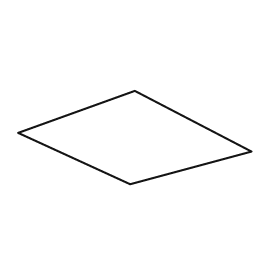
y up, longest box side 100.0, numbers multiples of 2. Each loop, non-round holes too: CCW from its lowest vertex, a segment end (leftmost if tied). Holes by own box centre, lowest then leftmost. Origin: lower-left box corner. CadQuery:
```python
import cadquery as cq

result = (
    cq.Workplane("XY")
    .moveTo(48.0, 0.0)
    .lineTo(100.0, 14.0)
    .lineTo(50.0, 40.0)
    .lineTo(0.0, 22.0)
    .close()
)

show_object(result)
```